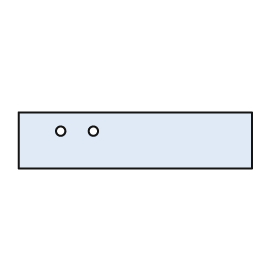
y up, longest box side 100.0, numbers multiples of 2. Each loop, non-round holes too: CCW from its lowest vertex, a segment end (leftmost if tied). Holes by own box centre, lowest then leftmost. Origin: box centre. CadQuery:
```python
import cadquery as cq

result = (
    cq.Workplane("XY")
    .moveTo(-50.0, -12.0)
    .lineTo(50.0, -12.0)
    .lineTo(50.0, 12.0)
    .lineTo(-50.0, 12.0)
    .close()
    .moveTo(-32.0, 4.0)
    .circle(2.0)
    .moveTo(-18.0, 4.0)
    .circle(2.0)
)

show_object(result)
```